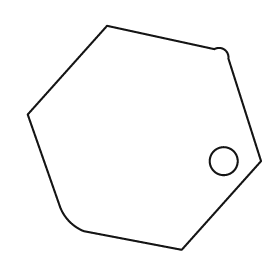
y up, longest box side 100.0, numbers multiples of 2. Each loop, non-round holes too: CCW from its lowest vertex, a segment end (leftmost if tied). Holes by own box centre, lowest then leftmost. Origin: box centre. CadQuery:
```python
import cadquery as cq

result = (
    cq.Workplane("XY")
    .moveTo(16.0, -48.0)
    .lineTo(50.0, -10.0)
    .lineTo(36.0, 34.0)
    .threePointArc((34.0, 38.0), (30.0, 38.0))
    .lineTo(-16.0, 48.0)
    .lineTo(-50.0, 10.0)
    .lineTo(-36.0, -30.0)
    .threePointArc((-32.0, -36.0), (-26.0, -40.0))
    .close()
    .moveTo(34.0, -10.0)
    .circle(6.0)
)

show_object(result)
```